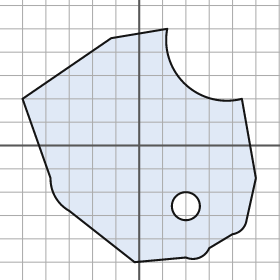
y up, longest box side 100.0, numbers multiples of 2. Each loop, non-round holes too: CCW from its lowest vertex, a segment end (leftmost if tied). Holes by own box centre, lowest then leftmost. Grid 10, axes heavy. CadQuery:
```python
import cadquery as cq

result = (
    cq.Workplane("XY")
    .moveTo(-2.0, -50.0)
    .lineTo(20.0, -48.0)
    .threePointArc((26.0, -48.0), (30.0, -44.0))
    .lineTo(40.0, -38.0)
    .threePointArc((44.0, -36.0), (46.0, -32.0))
    .lineTo(50.0, -14.0)
    .lineTo(44.0, 20.0)
    .threePointArc((20.0, 26.0), (12.0, 50.0))
    .lineTo(-12.0, 46.0)
    .lineTo(-50.0, 20.0)
    .lineTo(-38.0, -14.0)
    .threePointArc((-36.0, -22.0), (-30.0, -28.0))
    .close()
    .moveTo(20.0, -26.0)
    .circle(6.0)
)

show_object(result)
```